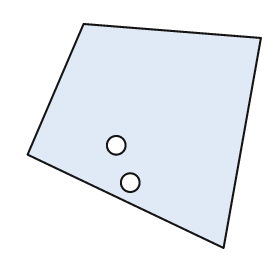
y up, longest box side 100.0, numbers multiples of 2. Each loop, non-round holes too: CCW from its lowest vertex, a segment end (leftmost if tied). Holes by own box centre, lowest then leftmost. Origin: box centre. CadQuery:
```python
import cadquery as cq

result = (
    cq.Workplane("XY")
    .moveTo(34.0, -48.0)
    .lineTo(50.0, 42.0)
    .lineTo(-26.0, 48.0)
    .lineTo(-50.0, -8.0)
    .close()
    .moveTo(-6.0, -20.0)
    .circle(4.0)
    .moveTo(-12.0, -4.0)
    .circle(4.0)
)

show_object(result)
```